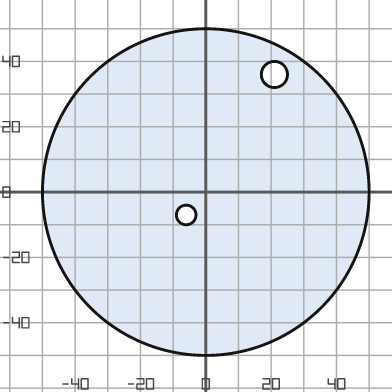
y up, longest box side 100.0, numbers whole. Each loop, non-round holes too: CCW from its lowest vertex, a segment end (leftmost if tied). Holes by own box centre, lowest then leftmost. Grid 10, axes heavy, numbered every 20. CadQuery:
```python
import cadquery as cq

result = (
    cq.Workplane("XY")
    .moveTo(0.0, 0.0)
    .circle(50.0)
    .moveTo(-6.0, -7.0)
    .circle(3.0)
    .moveTo(21.0, 36.0)
    .circle(4.0)
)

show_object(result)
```